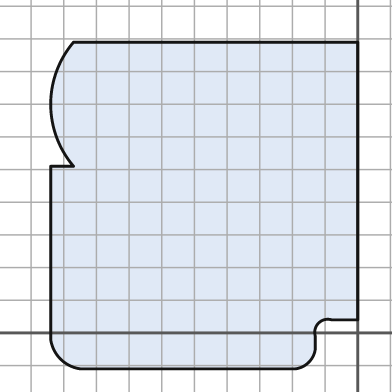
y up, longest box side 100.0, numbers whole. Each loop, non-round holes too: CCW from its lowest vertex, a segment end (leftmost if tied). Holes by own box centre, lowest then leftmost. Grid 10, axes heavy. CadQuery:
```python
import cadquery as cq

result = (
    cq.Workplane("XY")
    .moveTo(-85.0, -11.0)
    .lineTo(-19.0, -11.0)
    .threePointArc((-15.0, -9.0), (-13.0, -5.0))
    .lineTo(-13.0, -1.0)
    .threePointArc((-12.0, 3.0), (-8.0, 4.0))
    .lineTo(0.0, 4.0)
    .lineTo(0.0, 89.0)
    .lineTo(-87.0, 89.0)
    .threePointArc((-94.0, 70.0), (-87.0, 51.0))
    .lineTo(-94.0, 51.0)
    .lineTo(-94.0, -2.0)
    .threePointArc((-91.0, -8.0), (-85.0, -11.0))
    .close()
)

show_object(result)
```